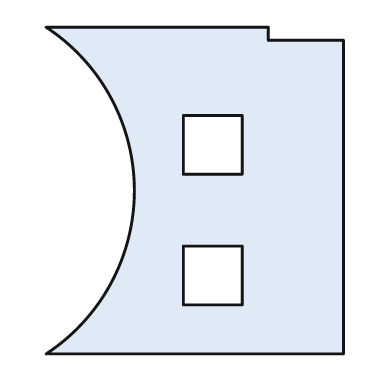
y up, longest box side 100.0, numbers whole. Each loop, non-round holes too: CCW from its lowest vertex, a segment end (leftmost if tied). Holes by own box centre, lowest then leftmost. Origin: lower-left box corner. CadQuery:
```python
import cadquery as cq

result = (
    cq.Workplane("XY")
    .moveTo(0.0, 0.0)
    .lineTo(91.0, 0.0)
    .lineTo(91.0, 96.0)
    .lineTo(68.0, 96.0)
    .lineTo(68.0, 100.0)
    .lineTo(0.0, 100.0)
    .threePointArc((27.0, 50.0), (0.0, 0.0))
    .close()
    .moveTo(42.0, 15.0)
    .lineTo(60.0, 15.0)
    .lineTo(60.0, 33.0)
    .lineTo(42.0, 33.0)
    .close()
    .moveTo(42.0, 55.0)
    .lineTo(60.0, 55.0)
    .lineTo(60.0, 73.0)
    .lineTo(42.0, 73.0)
    .close()
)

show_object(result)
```